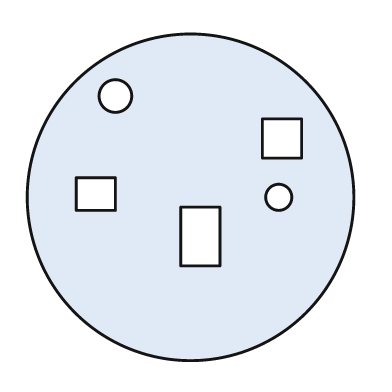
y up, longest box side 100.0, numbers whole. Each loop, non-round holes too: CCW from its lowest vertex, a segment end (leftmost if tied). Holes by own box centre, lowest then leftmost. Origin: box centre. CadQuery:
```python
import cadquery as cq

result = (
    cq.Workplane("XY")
    .moveTo(0.0, 0.0)
    .circle(50.0)
    .moveTo(-3.0, -21.0)
    .lineTo(9.0, -21.0)
    .lineTo(9.0, -3.0)
    .lineTo(-3.0, -3.0)
    .close()
    .moveTo(27.0, 0.0)
    .circle(4.0)
    .moveTo(-35.0, -4.0)
    .lineTo(-23.0, -4.0)
    .lineTo(-23.0, 6.0)
    .lineTo(-35.0, 6.0)
    .close()
    .moveTo(22.0, 12.0)
    .lineTo(34.0, 12.0)
    .lineTo(34.0, 24.0)
    .lineTo(22.0, 24.0)
    .close()
    .moveTo(-23.0, 31.0)
    .circle(5.0)
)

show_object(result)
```